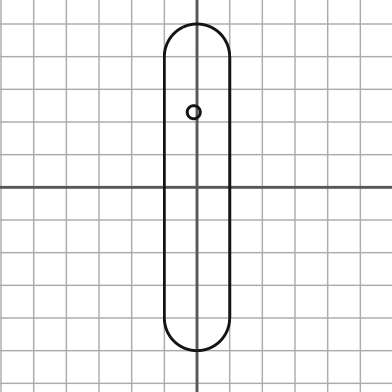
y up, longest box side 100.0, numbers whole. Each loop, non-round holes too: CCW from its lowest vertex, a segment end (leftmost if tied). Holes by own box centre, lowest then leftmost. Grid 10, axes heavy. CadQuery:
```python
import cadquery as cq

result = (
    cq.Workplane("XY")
    .moveTo(-10.0, -40.0)
    .threePointArc((0.0, -50.0), (10.0, -40.0))
    .lineTo(10.0, 40.0)
    .threePointArc((0.0, 50.0), (-10.0, 40.0))
    .close()
    .moveTo(-1.0, 23.0)
    .circle(2.0)
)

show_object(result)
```